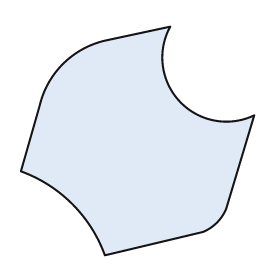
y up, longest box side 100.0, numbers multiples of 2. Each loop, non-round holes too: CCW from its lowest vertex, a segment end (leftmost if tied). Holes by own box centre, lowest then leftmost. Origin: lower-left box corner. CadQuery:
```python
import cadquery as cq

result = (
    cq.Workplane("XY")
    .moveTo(36.0, 0.0)
    .lineTo(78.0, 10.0)
    .threePointArc((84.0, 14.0), (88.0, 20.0))
    .lineTo(100.0, 60.0)
    .threePointArc((68.0, 66.0), (64.0, 98.0))
    .lineTo(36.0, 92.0)
    .threePointArc((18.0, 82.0), (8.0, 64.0))
    .lineTo(0.0, 36.0)
    .threePointArc((22.0, 22.0), (36.0, 0.0))
    .close()
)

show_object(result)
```